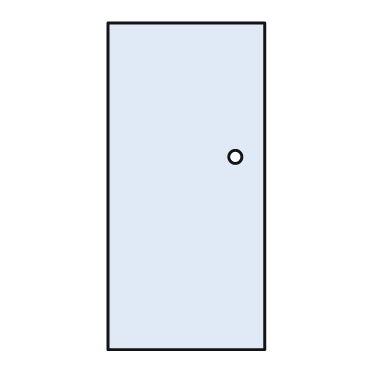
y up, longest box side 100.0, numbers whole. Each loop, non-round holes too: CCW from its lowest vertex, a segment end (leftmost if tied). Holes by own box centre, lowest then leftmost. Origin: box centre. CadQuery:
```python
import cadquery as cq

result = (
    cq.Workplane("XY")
    .moveTo(-24.0, -50.0)
    .lineTo(24.0, -50.0)
    .lineTo(24.0, 50.0)
    .lineTo(-24.0, 50.0)
    .close()
    .moveTo(15.0, 9.0)
    .circle(2.0)
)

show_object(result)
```